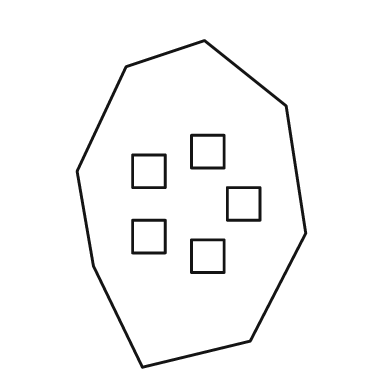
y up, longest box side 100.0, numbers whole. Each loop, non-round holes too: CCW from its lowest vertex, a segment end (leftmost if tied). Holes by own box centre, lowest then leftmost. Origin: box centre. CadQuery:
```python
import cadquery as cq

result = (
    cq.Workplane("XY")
    .moveTo(-15.0, -50.0)
    .lineTo(18.0, -42.0)
    .lineTo(35.0, -9.0)
    .lineTo(29.0, 30.0)
    .lineTo(4.0, 50.0)
    .lineTo(-20.0, 42.0)
    .lineTo(-35.0, 10.0)
    .lineTo(-30.0, -19.0)
    .close()
    .moveTo(0.0, -21.0)
    .lineTo(10.0, -21.0)
    .lineTo(10.0, -11.0)
    .lineTo(0.0, -11.0)
    .close()
    .moveTo(-18.0, -15.0)
    .lineTo(-8.0, -15.0)
    .lineTo(-8.0, -5.0)
    .lineTo(-18.0, -5.0)
    .close()
    .moveTo(11.0, -5.0)
    .lineTo(21.0, -5.0)
    .lineTo(21.0, 5.0)
    .lineTo(11.0, 5.0)
    .close()
    .moveTo(-18.0, 5.0)
    .lineTo(-8.0, 5.0)
    .lineTo(-8.0, 15.0)
    .lineTo(-18.0, 15.0)
    .close()
    .moveTo(0.0, 11.0)
    .lineTo(10.0, 11.0)
    .lineTo(10.0, 21.0)
    .lineTo(0.0, 21.0)
    .close()
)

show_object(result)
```